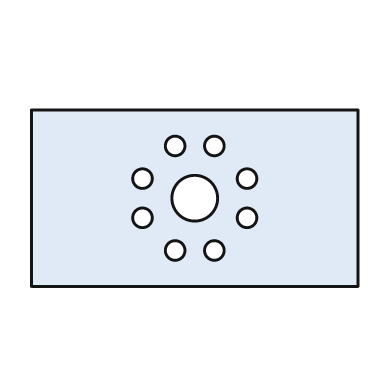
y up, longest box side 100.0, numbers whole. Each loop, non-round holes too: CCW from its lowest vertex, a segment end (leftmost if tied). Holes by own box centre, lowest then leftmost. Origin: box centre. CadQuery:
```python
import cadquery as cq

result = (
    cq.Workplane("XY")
    .moveTo(-50.0, -27.0)
    .lineTo(50.0, -27.0)
    .lineTo(50.0, 27.0)
    .lineTo(-50.0, 27.0)
    .close()
    .moveTo(-6.0, -16.0)
    .circle(3.0)
    .moveTo(6.0, -16.0)
    .circle(3.0)
    .moveTo(-16.0, -6.0)
    .circle(3.0)
    .moveTo(16.0, -6.0)
    .circle(3.0)
    .moveTo(0.0, 0.0)
    .circle(7.0)
    .moveTo(-16.0, 6.0)
    .circle(3.0)
    .moveTo(16.0, 6.0)
    .circle(3.0)
    .moveTo(-6.0, 16.0)
    .circle(3.0)
    .moveTo(6.0, 16.0)
    .circle(3.0)
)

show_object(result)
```